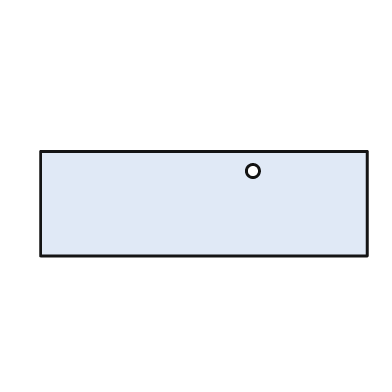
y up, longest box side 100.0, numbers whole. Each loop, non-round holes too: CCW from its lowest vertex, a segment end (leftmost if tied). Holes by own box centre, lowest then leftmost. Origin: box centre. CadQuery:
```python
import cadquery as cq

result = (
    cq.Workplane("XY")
    .moveTo(-50.0, -16.0)
    .lineTo(50.0, -16.0)
    .lineTo(50.0, 16.0)
    .lineTo(-50.0, 16.0)
    .close()
    .moveTo(15.0, 10.0)
    .circle(2.0)
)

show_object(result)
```